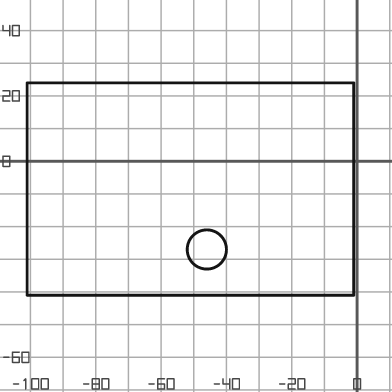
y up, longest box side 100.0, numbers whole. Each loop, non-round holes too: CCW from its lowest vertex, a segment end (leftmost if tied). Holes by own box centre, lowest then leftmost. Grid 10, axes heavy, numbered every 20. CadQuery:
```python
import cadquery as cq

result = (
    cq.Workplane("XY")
    .moveTo(-101.0, -41.0)
    .lineTo(-1.0, -41.0)
    .lineTo(-1.0, 24.0)
    .lineTo(-101.0, 24.0)
    .close()
    .moveTo(-46.0, -27.0)
    .circle(6.0)
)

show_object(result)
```